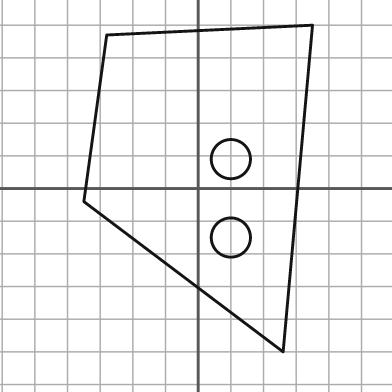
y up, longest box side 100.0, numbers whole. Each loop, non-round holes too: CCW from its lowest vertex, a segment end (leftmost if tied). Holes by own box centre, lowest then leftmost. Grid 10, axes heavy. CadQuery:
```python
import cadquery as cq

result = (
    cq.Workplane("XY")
    .moveTo(26.0, -50.0)
    .lineTo(35.0, 50.0)
    .lineTo(-28.0, 47.0)
    .lineTo(-35.0, -4.0)
    .close()
    .moveTo(10.0, -15.0)
    .circle(6.0)
    .moveTo(10.0, 9.0)
    .circle(6.0)
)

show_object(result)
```